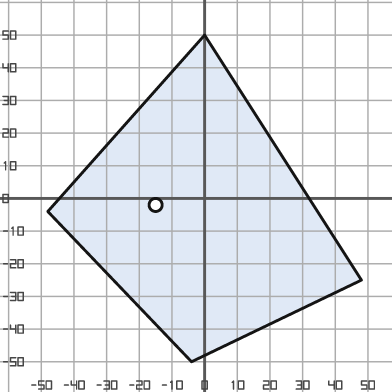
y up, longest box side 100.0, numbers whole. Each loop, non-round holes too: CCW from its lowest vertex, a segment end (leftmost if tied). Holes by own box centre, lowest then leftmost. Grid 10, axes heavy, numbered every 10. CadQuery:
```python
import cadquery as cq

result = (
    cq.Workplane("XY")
    .moveTo(-4.0, -50.0)
    .lineTo(48.0, -25.0)
    .lineTo(0.0, 50.0)
    .lineTo(-48.0, -4.0)
    .close()
    .moveTo(-15.0, -2.0)
    .circle(2.0)
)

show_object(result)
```